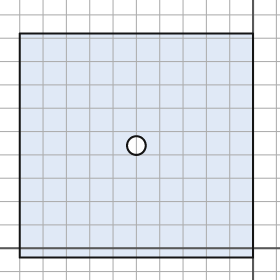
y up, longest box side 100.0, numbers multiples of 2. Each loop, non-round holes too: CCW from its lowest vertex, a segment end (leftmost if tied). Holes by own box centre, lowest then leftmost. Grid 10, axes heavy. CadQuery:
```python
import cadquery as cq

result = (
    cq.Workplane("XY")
    .moveTo(-100.0, -4.0)
    .lineTo(0.0, -4.0)
    .lineTo(0.0, 92.0)
    .lineTo(-100.0, 92.0)
    .close()
    .moveTo(-50.0, 44.0)
    .circle(4.0)
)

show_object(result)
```